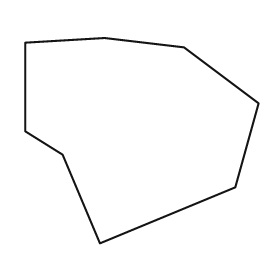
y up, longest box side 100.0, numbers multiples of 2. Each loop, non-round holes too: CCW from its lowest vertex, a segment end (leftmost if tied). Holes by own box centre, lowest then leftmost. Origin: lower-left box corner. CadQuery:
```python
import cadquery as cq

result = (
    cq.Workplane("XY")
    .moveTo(32.0, 0.0)
    .lineTo(90.0, 24.0)
    .lineTo(100.0, 60.0)
    .lineTo(68.0, 84.0)
    .lineTo(34.0, 88.0)
    .lineTo(0.0, 86.0)
    .lineTo(0.0, 48.0)
    .lineTo(16.0, 38.0)
    .close()
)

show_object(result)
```